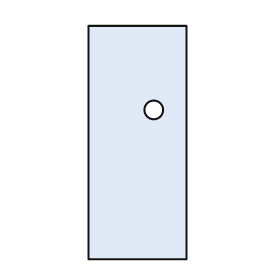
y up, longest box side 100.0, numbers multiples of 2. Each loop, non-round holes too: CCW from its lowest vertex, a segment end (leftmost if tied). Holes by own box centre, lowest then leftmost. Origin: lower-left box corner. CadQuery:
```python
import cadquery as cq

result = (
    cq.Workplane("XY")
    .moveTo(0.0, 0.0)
    .lineTo(42.0, 0.0)
    .lineTo(42.0, 100.0)
    .lineTo(0.0, 100.0)
    .close()
    .moveTo(28.0, 64.0)
    .circle(4.0)
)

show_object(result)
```